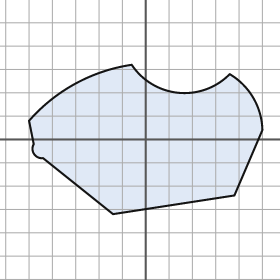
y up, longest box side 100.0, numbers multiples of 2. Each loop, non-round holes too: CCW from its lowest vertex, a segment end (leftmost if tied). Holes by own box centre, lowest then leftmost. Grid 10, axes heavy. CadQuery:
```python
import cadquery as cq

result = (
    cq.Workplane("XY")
    .moveTo(-14.0, -32.0)
    .lineTo(38.0, -24.0)
    .lineTo(50.0, 4.0)
    .threePointArc((46.0, 18.0), (36.0, 28.0))
    .threePointArc((14.0, 20.0), (-6.0, 32.0))
    .threePointArc((-30.0, 24.0), (-50.0, 8.0))
    .lineTo(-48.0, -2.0)
    .threePointArc((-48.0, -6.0), (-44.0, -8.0))
    .close()
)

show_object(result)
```